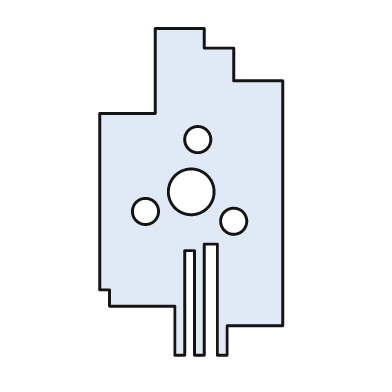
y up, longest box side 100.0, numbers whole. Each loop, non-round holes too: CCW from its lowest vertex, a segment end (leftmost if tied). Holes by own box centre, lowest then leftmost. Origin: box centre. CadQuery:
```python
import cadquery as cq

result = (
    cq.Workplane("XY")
    .moveTo(-5.0, -50.0)
    .lineTo(-2.0, -50.0)
    .lineTo(-2.0, -18.0)
    .lineTo(1.0, -18.0)
    .lineTo(1.0, -50.0)
    .lineTo(4.0, -50.0)
    .lineTo(4.0, -16.0)
    .lineTo(8.0, -16.0)
    .lineTo(8.0, -50.0)
    .lineTo(11.0, -50.0)
    .lineTo(11.0, -41.0)
    .lineTo(28.0, -41.0)
    .lineTo(28.0, 34.0)
    .lineTo(13.0, 34.0)
    .lineTo(13.0, 44.0)
    .lineTo(4.0, 44.0)
    .lineTo(4.0, 50.0)
    .lineTo(-11.0, 50.0)
    .lineTo(-11.0, 24.0)
    .lineTo(-28.0, 24.0)
    .lineTo(-28.0, -30.0)
    .lineTo(-25.0, -30.0)
    .lineTo(-25.0, -35.0)
    .lineTo(-5.0, -35.0)
    .close()
    .moveTo(13.0, -9.0)
    .circle(4.0)
    .moveTo(-14.0, -6.0)
    .circle(4.0)
    .moveTo(0.0, 0.0)
    .circle(7.0)
    .moveTo(2.0, 16.0)
    .circle(4.0)
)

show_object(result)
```